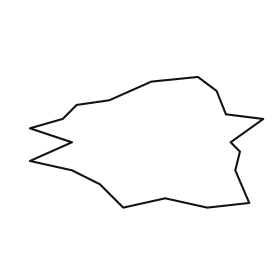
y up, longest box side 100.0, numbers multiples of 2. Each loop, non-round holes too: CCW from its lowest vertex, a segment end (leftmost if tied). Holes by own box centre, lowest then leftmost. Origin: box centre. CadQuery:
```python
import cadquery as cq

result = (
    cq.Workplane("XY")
    .moveTo(-10.0, -28.0)
    .lineTo(8.0, -24.0)
    .lineTo(26.0, -28.0)
    .lineTo(44.0, -26.0)
    .lineTo(38.0, -12.0)
    .lineTo(40.0, -4.0)
    .lineTo(36.0, 0.0)
    .lineTo(50.0, 10.0)
    .lineTo(34.0, 12.0)
    .lineTo(30.0, 22.0)
    .lineTo(22.0, 28.0)
    .lineTo(2.0, 26.0)
    .lineTo(-16.0, 18.0)
    .lineTo(-30.0, 16.0)
    .lineTo(-36.0, 10.0)
    .lineTo(-50.0, 6.0)
    .lineTo(-32.0, 0.0)
    .lineTo(-50.0, -8.0)
    .lineTo(-32.0, -12.0)
    .lineTo(-20.0, -18.0)
    .close()
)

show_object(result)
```